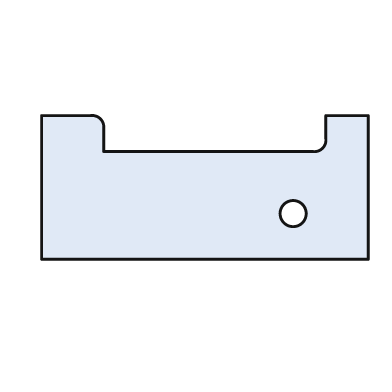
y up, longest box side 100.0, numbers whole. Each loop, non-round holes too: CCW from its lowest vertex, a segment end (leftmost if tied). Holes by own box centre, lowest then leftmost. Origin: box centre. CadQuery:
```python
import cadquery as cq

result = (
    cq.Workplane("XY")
    .moveTo(-50.0, -22.0)
    .lineTo(50.0, -22.0)
    .lineTo(50.0, 22.0)
    .lineTo(37.0, 22.0)
    .lineTo(37.0, 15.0)
    .threePointArc((36.0, 12.0), (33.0, 11.0))
    .lineTo(-31.0, 11.0)
    .lineTo(-31.0, 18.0)
    .threePointArc((-32.0, 21.0), (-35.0, 22.0))
    .lineTo(-50.0, 22.0)
    .close()
    .moveTo(27.0, -8.0)
    .circle(4.0)
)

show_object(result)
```